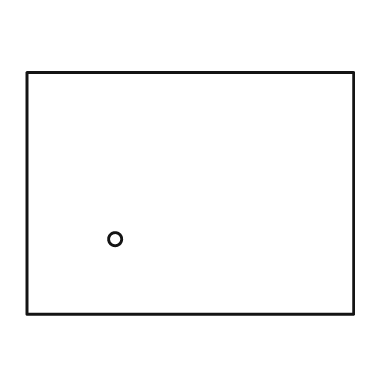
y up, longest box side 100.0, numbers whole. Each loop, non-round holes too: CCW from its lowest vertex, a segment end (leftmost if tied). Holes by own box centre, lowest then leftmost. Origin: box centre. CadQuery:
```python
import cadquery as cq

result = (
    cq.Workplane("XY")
    .moveTo(-50.0, -37.0)
    .lineTo(50.0, -37.0)
    .lineTo(50.0, 37.0)
    .lineTo(-50.0, 37.0)
    .close()
    .moveTo(-23.0, -14.0)
    .circle(2.0)
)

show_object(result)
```